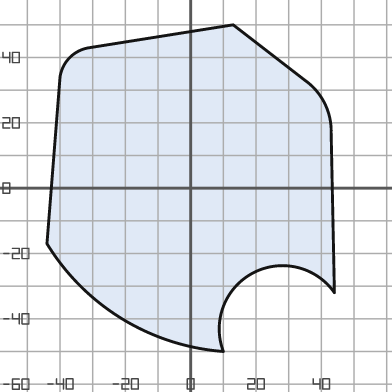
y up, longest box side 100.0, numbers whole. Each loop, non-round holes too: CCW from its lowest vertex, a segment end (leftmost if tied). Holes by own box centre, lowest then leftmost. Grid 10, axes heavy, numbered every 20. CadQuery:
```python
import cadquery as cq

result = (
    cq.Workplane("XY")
    .moveTo(10.0, -50.0)
    .threePointArc((19.0, -26.0), (44.0, -32.0))
    .lineTo(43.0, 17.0)
    .threePointArc((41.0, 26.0), (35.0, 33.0))
    .lineTo(13.0, 50.0)
    .lineTo(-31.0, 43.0)
    .threePointArc((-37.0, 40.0), (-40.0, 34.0))
    .lineTo(-44.0, -17.0)
    .threePointArc((-21.0, -40.0), (10.0, -50.0))
    .close()
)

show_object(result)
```